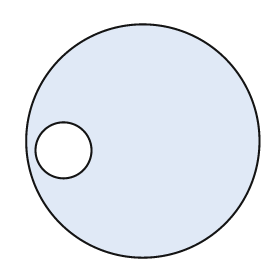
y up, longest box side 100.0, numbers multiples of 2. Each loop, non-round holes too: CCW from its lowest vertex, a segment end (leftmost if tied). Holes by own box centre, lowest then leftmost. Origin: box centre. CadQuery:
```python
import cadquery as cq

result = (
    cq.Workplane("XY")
    .moveTo(0.0, 0.0)
    .circle(50.0)
    .moveTo(-34.0, -4.0)
    .circle(12.0)
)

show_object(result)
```